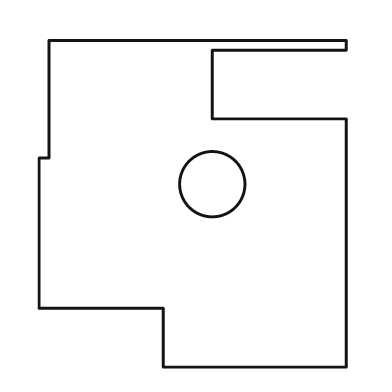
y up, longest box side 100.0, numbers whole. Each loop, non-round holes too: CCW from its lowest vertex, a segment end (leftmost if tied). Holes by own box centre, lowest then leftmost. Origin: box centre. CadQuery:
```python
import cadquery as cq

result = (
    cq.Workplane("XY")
    .moveTo(-9.0, -50.0)
    .lineTo(47.0, -50.0)
    .lineTo(47.0, 26.0)
    .lineTo(6.0, 26.0)
    .lineTo(6.0, 47.0)
    .lineTo(47.0, 47.0)
    .lineTo(47.0, 50.0)
    .lineTo(-44.0, 50.0)
    .lineTo(-44.0, 14.0)
    .lineTo(-47.0, 14.0)
    .lineTo(-47.0, -32.0)
    .lineTo(-9.0, -32.0)
    .close()
    .moveTo(6.0, 6.0)
    .circle(10.0)
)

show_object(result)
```